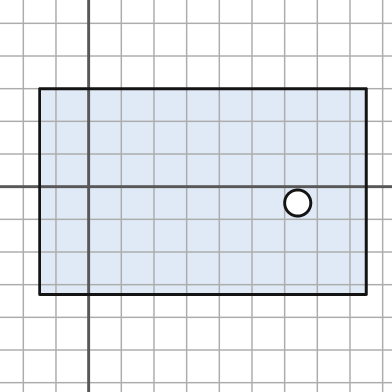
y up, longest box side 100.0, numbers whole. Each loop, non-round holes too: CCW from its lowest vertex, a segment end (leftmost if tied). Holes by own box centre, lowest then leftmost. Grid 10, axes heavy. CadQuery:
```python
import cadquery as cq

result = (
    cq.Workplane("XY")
    .moveTo(-15.0, -33.0)
    .lineTo(85.0, -33.0)
    .lineTo(85.0, 30.0)
    .lineTo(-15.0, 30.0)
    .close()
    .moveTo(64.0, -5.0)
    .circle(4.0)
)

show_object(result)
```